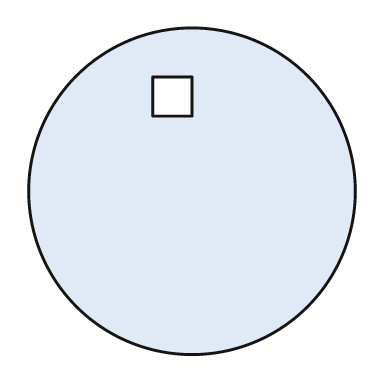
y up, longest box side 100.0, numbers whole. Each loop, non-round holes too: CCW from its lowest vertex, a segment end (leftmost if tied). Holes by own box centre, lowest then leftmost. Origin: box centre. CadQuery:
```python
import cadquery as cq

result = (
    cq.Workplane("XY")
    .moveTo(0.0, 0.0)
    .circle(50.0)
    .moveTo(-12.0, 23.0)
    .lineTo(0.0, 23.0)
    .lineTo(0.0, 35.0)
    .lineTo(-12.0, 35.0)
    .close()
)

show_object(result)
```